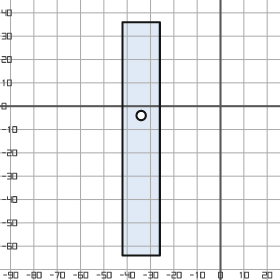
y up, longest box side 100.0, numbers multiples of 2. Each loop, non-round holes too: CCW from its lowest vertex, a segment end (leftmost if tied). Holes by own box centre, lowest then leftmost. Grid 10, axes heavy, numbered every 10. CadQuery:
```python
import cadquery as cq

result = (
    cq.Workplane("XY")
    .moveTo(-42.0, -64.0)
    .lineTo(-26.0, -64.0)
    .lineTo(-26.0, 36.0)
    .lineTo(-42.0, 36.0)
    .close()
    .moveTo(-34.0, -4.0)
    .circle(2.0)
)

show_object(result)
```